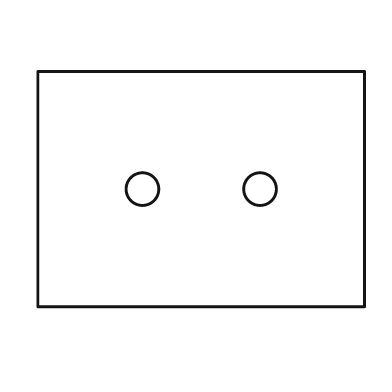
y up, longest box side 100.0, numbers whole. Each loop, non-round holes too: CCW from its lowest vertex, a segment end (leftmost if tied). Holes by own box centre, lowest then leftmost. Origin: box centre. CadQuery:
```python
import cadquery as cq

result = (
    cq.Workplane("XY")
    .moveTo(-50.0, -36.0)
    .lineTo(50.0, -36.0)
    .lineTo(50.0, 36.0)
    .lineTo(-50.0, 36.0)
    .close()
    .moveTo(-18.0, 0.0)
    .circle(5.0)
    .moveTo(18.0, 0.0)
    .circle(5.0)
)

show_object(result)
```